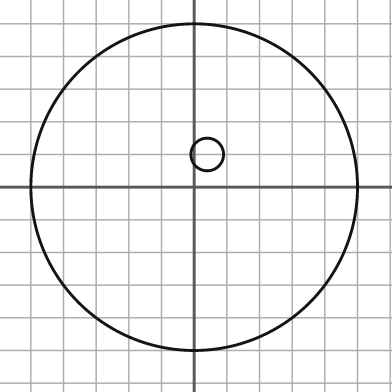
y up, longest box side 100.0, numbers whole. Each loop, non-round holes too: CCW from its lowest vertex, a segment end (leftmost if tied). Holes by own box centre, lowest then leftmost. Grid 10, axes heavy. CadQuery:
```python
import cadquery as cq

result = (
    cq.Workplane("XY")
    .moveTo(0.0, 0.0)
    .circle(50.0)
    .moveTo(4.0, 10.0)
    .circle(5.0)
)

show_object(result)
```